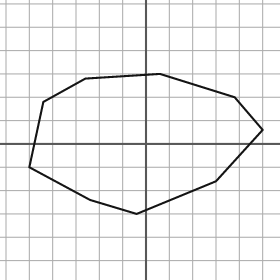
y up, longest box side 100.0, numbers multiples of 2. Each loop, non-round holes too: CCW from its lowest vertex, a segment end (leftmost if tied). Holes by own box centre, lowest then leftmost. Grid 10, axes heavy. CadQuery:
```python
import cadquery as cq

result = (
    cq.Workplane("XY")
    .moveTo(-4.0, -30.0)
    .lineTo(30.0, -16.0)
    .lineTo(50.0, 6.0)
    .lineTo(38.0, 20.0)
    .lineTo(6.0, 30.0)
    .lineTo(-26.0, 28.0)
    .lineTo(-44.0, 18.0)
    .lineTo(-50.0, -10.0)
    .lineTo(-24.0, -24.0)
    .close()
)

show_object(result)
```